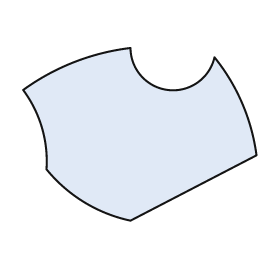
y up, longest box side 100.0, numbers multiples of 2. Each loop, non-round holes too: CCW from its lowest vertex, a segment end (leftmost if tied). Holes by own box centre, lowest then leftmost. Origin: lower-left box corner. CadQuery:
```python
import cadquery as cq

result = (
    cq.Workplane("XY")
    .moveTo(46.0, 0.0)
    .lineTo(100.0, 28.0)
    .threePointArc((94.0, 50.0), (82.0, 70.0))
    .threePointArc((62.0, 56.0), (46.0, 74.0))
    .threePointArc((22.0, 68.0), (0.0, 56.0))
    .threePointArc((8.0, 40.0), (10.0, 22.0))
    .threePointArc((26.0, 8.0), (46.0, 0.0))
    .close()
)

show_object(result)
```